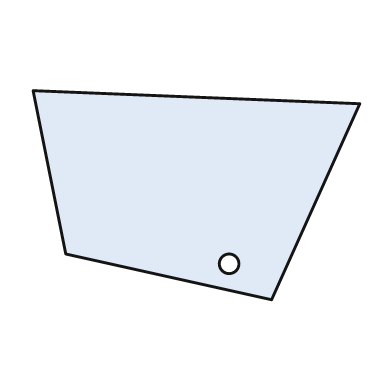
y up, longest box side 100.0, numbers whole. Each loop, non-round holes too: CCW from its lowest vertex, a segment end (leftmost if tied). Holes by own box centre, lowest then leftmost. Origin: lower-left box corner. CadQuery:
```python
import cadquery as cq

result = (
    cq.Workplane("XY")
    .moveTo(73.0, 0.0)
    .lineTo(100.0, 60.0)
    .lineTo(0.0, 64.0)
    .lineTo(10.0, 14.0)
    .close()
    .moveTo(60.0, 11.0)
    .circle(3.0)
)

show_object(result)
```